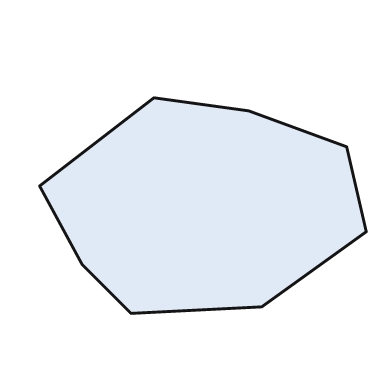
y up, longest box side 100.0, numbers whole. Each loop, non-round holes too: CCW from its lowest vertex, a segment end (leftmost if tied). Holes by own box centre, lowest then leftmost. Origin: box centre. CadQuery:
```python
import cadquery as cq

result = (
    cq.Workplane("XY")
    .moveTo(-22.0, -33.0)
    .lineTo(18.0, -31.0)
    .lineTo(50.0, -8.0)
    .lineTo(44.0, 18.0)
    .lineTo(14.0, 29.0)
    .lineTo(-15.0, 33.0)
    .lineTo(-50.0, 6.0)
    .lineTo(-37.0, -18.0)
    .close()
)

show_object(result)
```